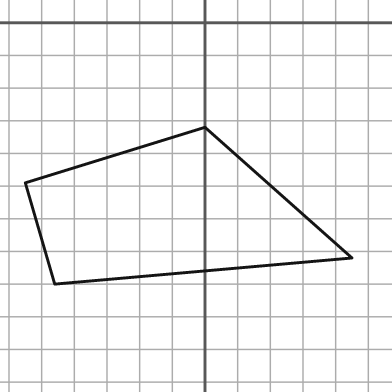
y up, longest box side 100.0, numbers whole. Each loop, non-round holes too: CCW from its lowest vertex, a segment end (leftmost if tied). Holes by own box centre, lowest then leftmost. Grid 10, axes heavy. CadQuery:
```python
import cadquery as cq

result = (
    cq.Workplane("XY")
    .moveTo(-46.0, -80.0)
    .lineTo(45.0, -72.0)
    .lineTo(0.0, -32.0)
    .lineTo(-55.0, -49.0)
    .close()
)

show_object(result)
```